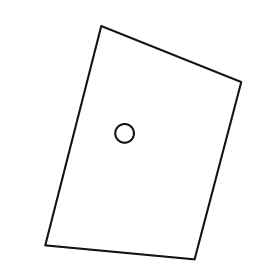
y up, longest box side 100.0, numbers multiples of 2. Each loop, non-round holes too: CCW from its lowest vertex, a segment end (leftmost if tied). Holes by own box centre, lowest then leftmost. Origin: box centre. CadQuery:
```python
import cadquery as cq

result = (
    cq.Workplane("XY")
    .moveTo(22.0, -50.0)
    .lineTo(42.0, 26.0)
    .lineTo(-18.0, 50.0)
    .lineTo(-42.0, -44.0)
    .close()
    .moveTo(-8.0, 4.0)
    .circle(4.0)
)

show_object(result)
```